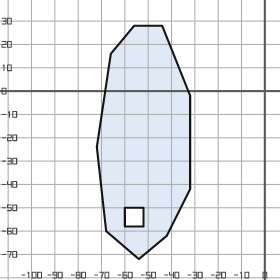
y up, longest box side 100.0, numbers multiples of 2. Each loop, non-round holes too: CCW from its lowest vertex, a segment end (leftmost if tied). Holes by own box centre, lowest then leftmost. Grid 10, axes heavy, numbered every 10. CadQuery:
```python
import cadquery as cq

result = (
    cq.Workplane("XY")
    .moveTo(-54.0, -72.0)
    .lineTo(-42.0, -62.0)
    .lineTo(-32.0, -42.0)
    .lineTo(-32.0, -2.0)
    .lineTo(-44.0, 28.0)
    .lineTo(-56.0, 28.0)
    .lineTo(-66.0, 16.0)
    .lineTo(-72.0, -24.0)
    .lineTo(-68.0, -60.0)
    .close()
    .moveTo(-60.0, -58.0)
    .lineTo(-52.0, -58.0)
    .lineTo(-52.0, -50.0)
    .lineTo(-60.0, -50.0)
    .close()
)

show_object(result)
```